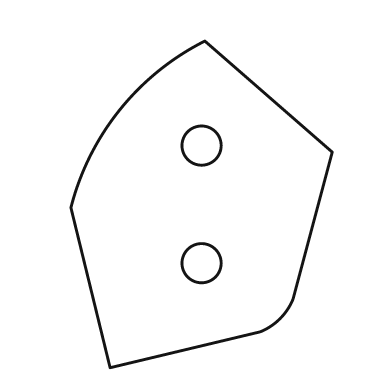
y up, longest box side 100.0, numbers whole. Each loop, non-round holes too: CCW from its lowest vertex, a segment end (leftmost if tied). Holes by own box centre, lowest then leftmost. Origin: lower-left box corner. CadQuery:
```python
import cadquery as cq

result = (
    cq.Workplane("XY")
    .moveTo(12.0, 0.0)
    .lineTo(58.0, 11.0)
    .threePointArc((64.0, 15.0), (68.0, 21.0))
    .lineTo(80.0, 66.0)
    .lineTo(41.0, 100.0)
    .threePointArc((15.0, 79.0), (0.0, 49.0))
    .close()
    .moveTo(40.0, 32.0)
    .circle(6.0)
    .moveTo(40.0, 68.0)
    .circle(6.0)
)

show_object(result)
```